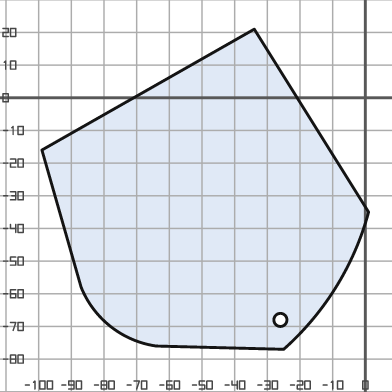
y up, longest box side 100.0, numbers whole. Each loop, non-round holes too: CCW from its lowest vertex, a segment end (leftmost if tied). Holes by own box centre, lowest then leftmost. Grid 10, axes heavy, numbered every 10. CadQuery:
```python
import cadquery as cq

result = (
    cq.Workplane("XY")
    .moveTo(-25.0, -77.0)
    .threePointArc((-9.0, -58.0), (1.0, -35.0))
    .lineTo(-34.0, 21.0)
    .lineTo(-99.0, -16.0)
    .lineTo(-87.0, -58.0)
    .threePointArc((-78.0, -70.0), (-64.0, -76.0))
    .close()
    .moveTo(-26.0, -68.0)
    .circle(2.0)
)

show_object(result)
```